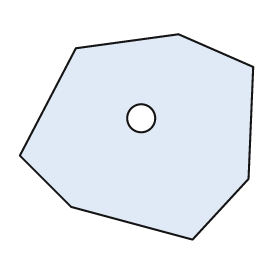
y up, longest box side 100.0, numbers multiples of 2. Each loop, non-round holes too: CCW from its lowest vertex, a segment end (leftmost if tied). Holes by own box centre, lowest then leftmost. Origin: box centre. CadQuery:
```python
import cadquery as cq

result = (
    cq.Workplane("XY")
    .moveTo(24.0, -44.0)
    .lineTo(48.0, -18.0)
    .lineTo(50.0, 30.0)
    .lineTo(18.0, 44.0)
    .lineTo(-26.0, 38.0)
    .lineTo(-50.0, -8.0)
    .lineTo(-28.0, -30.0)
    .close()
    .moveTo(2.0, 8.0)
    .circle(6.0)
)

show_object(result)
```